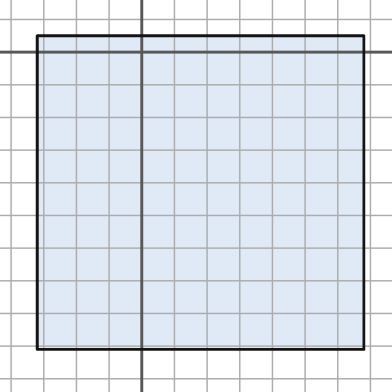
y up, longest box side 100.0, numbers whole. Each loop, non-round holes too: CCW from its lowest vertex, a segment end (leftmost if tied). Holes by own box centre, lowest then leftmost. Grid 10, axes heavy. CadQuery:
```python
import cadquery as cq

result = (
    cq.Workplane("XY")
    .moveTo(-32.0, -91.0)
    .lineTo(68.0, -91.0)
    .lineTo(68.0, 5.0)
    .lineTo(-32.0, 5.0)
    .close()
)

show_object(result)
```